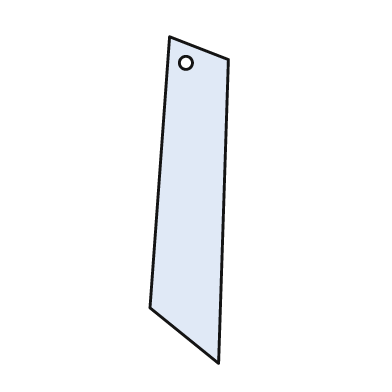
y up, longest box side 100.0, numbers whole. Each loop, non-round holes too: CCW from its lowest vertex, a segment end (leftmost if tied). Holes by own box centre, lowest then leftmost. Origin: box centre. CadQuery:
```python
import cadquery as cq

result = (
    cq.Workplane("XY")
    .moveTo(9.0, -50.0)
    .lineTo(12.0, 43.0)
    .lineTo(-6.0, 50.0)
    .lineTo(-12.0, -33.0)
    .close()
    .moveTo(-1.0, 42.0)
    .circle(2.0)
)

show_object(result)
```